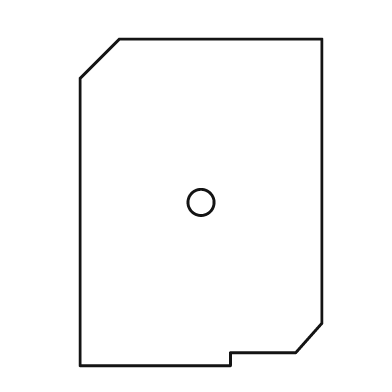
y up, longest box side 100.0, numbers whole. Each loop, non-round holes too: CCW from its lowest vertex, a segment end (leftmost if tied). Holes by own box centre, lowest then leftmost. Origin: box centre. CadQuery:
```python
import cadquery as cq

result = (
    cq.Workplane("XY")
    .moveTo(-37.0, -50.0)
    .lineTo(9.0, -50.0)
    .lineTo(9.0, -46.0)
    .lineTo(29.0, -46.0)
    .lineTo(37.0, -37.0)
    .lineTo(37.0, 50.0)
    .lineTo(-25.0, 50.0)
    .lineTo(-37.0, 38.0)
    .close()
    .moveTo(0.0, 0.0)
    .circle(4.0)
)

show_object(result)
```